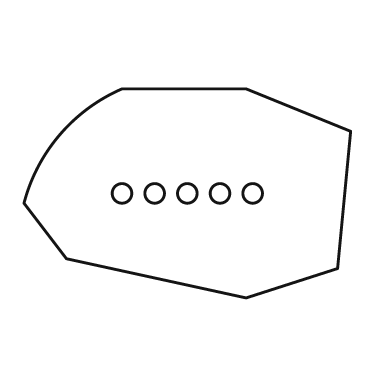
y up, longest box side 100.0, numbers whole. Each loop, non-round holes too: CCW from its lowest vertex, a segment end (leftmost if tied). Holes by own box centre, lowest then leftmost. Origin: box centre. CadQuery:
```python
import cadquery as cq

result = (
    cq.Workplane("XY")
    .moveTo(18.0, -32.0)
    .lineTo(46.0, -23.0)
    .lineTo(50.0, 19.0)
    .lineTo(18.0, 32.0)
    .lineTo(-20.0, 32.0)
    .threePointArc((-39.0, 18.0), (-50.0, -3.0))
    .lineTo(-37.0, -20.0)
    .close()
    .moveTo(-20.0, 0.0)
    .circle(3.0)
    .moveTo(-10.0, 0.0)
    .circle(3.0)
    .moveTo(0.0, 0.0)
    .circle(3.0)
    .moveTo(10.0, 0.0)
    .circle(3.0)
    .moveTo(20.0, 0.0)
    .circle(3.0)
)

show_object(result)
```